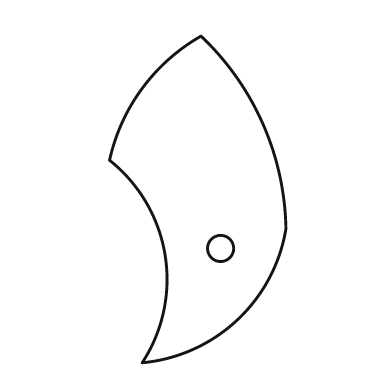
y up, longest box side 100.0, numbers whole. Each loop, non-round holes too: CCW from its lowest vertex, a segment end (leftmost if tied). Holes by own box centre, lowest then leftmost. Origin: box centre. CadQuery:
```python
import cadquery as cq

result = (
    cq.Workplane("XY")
    .moveTo(-17.0, -50.0)
    .threePointArc((12.0, -37.0), (27.0, -9.0))
    .threePointArc((20.0, 23.0), (1.0, 50.0))
    .threePointArc((-17.0, 34.0), (-27.0, 12.0))
    .threePointArc((-10.0, -17.0), (-17.0, -50.0))
    .close()
    .moveTo(7.0, -15.0)
    .circle(4.0)
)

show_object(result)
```